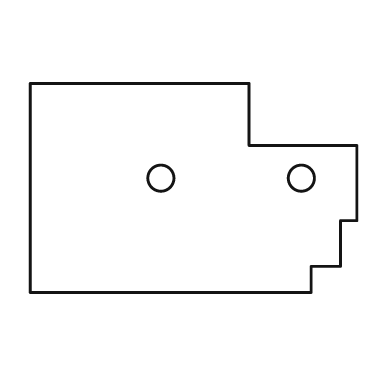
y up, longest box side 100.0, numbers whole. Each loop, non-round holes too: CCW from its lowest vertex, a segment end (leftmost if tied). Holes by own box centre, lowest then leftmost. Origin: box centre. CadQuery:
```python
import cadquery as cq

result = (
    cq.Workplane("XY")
    .moveTo(-50.0, -32.0)
    .lineTo(36.0, -32.0)
    .lineTo(36.0, -24.0)
    .lineTo(45.0, -24.0)
    .lineTo(45.0, -10.0)
    .lineTo(50.0, -10.0)
    .lineTo(50.0, 13.0)
    .lineTo(17.0, 13.0)
    .lineTo(17.0, 32.0)
    .lineTo(-50.0, 32.0)
    .close()
    .moveTo(-10.0, 3.0)
    .circle(4.0)
    .moveTo(33.0, 3.0)
    .circle(4.0)
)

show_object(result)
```